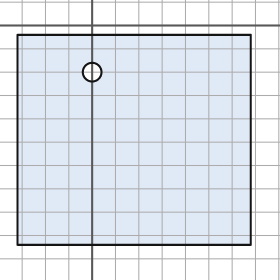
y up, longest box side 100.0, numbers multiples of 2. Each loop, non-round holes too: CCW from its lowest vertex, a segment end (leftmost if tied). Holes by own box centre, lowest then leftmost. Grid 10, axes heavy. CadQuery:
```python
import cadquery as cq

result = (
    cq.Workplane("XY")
    .moveTo(-32.0, -94.0)
    .lineTo(68.0, -94.0)
    .lineTo(68.0, -4.0)
    .lineTo(-32.0, -4.0)
    .close()
    .moveTo(0.0, -20.0)
    .circle(4.0)
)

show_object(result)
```